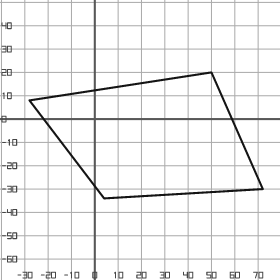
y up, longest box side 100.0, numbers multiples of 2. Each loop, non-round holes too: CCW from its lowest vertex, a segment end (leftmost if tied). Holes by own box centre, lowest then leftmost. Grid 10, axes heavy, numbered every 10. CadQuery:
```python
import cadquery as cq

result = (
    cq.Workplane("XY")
    .moveTo(4.0, -34.0)
    .lineTo(72.0, -30.0)
    .lineTo(50.0, 20.0)
    .lineTo(-28.0, 8.0)
    .close()
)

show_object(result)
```